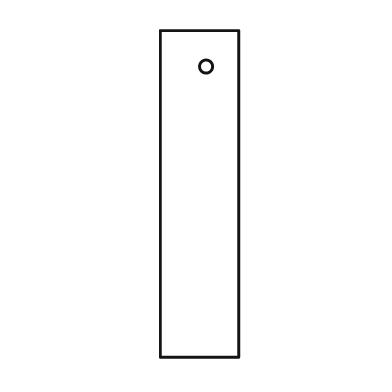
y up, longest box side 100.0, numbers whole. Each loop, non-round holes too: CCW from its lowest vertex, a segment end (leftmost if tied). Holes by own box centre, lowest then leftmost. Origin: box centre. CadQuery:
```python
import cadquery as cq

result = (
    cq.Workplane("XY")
    .moveTo(-12.0, -50.0)
    .lineTo(12.0, -50.0)
    .lineTo(12.0, 50.0)
    .lineTo(-12.0, 50.0)
    .close()
    .moveTo(2.0, 39.0)
    .circle(2.0)
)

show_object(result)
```